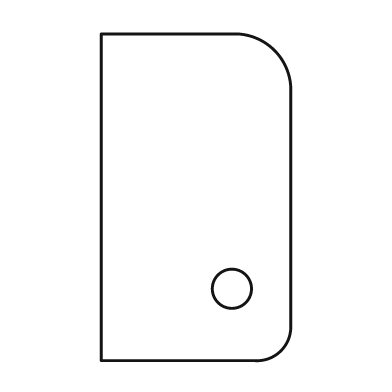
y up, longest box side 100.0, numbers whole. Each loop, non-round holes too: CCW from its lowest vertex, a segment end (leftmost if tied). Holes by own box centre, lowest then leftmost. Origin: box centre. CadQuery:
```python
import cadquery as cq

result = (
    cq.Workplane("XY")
    .moveTo(-29.0, -50.0)
    .lineTo(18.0, -50.0)
    .threePointArc((26.0, -47.0), (29.0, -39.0))
    .lineTo(29.0, 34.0)
    .threePointArc((24.0, 45.0), (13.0, 50.0))
    .lineTo(-29.0, 50.0)
    .close()
    .moveTo(11.0, -28.0)
    .circle(6.0)
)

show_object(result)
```